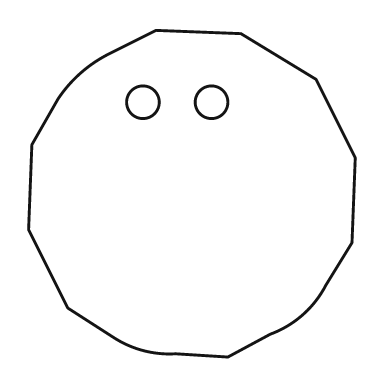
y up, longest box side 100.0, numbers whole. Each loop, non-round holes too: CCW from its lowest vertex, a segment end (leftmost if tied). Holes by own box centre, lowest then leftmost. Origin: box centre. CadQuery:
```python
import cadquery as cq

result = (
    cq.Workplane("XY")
    .moveTo(11.0, -50.0)
    .lineTo(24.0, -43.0)
    .threePointArc((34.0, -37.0), (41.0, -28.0))
    .lineTo(49.0, -15.0)
    .lineTo(50.0, 11.0)
    .lineTo(38.0, 35.0)
    .lineTo(15.0, 49.0)
    .lineTo(-11.0, 50.0)
    .lineTo(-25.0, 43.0)
    .threePointArc((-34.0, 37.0), (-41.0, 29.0))
    .lineTo(-49.0, 15.0)
    .lineTo(-50.0, -11.0)
    .lineTo(-38.0, -35.0)
    .lineTo(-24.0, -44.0)
    .threePointArc((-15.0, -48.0), (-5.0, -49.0))
    .close()
    .moveTo(-15.0, 28.0)
    .circle(5.0)
    .moveTo(6.0, 28.0)
    .circle(5.0)
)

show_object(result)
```